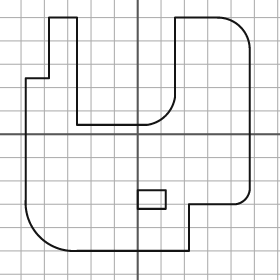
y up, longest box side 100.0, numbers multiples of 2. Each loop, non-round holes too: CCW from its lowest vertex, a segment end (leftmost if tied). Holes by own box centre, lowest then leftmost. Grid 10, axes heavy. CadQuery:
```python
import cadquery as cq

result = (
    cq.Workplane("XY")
    .moveTo(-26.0, -50.0)
    .lineTo(22.0, -50.0)
    .lineTo(22.0, -30.0)
    .lineTo(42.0, -30.0)
    .threePointArc((46.0, -28.0), (48.0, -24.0))
    .lineTo(48.0, 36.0)
    .threePointArc((44.0, 46.0), (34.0, 50.0))
    .lineTo(16.0, 50.0)
    .lineTo(16.0, 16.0)
    .threePointArc((12.0, 8.0), (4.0, 4.0))
    .lineTo(-26.0, 4.0)
    .lineTo(-26.0, 50.0)
    .lineTo(-38.0, 50.0)
    .lineTo(-38.0, 24.0)
    .lineTo(-48.0, 24.0)
    .lineTo(-48.0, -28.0)
    .threePointArc((-42.0, -44.0), (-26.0, -50.0))
    .close()
    .moveTo(0.0, -32.0)
    .lineTo(12.0, -32.0)
    .lineTo(12.0, -24.0)
    .lineTo(0.0, -24.0)
    .close()
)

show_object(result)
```